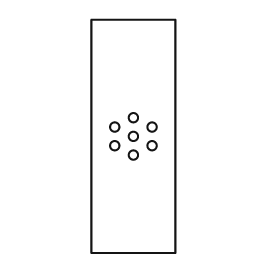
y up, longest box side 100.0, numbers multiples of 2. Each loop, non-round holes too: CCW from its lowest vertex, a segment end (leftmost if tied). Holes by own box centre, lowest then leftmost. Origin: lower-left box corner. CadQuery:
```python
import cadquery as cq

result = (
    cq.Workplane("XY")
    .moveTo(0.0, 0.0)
    .lineTo(36.0, 0.0)
    .lineTo(36.0, 100.0)
    .lineTo(0.0, 100.0)
    .close()
    .moveTo(18.0, 42.0)
    .circle(2.0)
    .moveTo(10.0, 46.0)
    .circle(2.0)
    .moveTo(26.0, 46.0)
    .circle(2.0)
    .moveTo(18.0, 50.0)
    .circle(2.0)
    .moveTo(10.0, 54.0)
    .circle(2.0)
    .moveTo(26.0, 54.0)
    .circle(2.0)
    .moveTo(18.0, 58.0)
    .circle(2.0)
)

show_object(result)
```